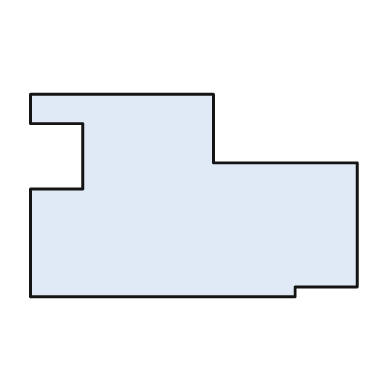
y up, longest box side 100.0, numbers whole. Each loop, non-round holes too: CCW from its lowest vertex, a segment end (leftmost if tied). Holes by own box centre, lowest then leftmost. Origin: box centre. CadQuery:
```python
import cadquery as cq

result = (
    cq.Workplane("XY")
    .moveTo(-50.0, -31.0)
    .lineTo(31.0, -31.0)
    .lineTo(31.0, -28.0)
    .lineTo(50.0, -28.0)
    .lineTo(50.0, 10.0)
    .lineTo(6.0, 10.0)
    .lineTo(6.0, 31.0)
    .lineTo(-50.0, 31.0)
    .lineTo(-50.0, 22.0)
    .lineTo(-34.0, 22.0)
    .lineTo(-34.0, 2.0)
    .lineTo(-50.0, 2.0)
    .close()
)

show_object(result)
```